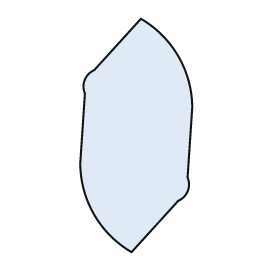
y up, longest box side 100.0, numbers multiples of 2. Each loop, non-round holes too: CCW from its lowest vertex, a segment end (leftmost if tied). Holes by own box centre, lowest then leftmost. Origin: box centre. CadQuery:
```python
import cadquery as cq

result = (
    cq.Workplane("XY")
    .moveTo(-2.0, -50.0)
    .lineTo(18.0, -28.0)
    .threePointArc((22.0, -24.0), (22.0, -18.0))
    .lineTo(24.0, 12.0)
    .threePointArc((18.0, 34.0), (2.0, 50.0))
    .lineTo(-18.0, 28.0)
    .threePointArc((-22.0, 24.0), (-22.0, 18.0))
    .lineTo(-24.0, -12.0)
    .threePointArc((-18.0, -34.0), (-2.0, -50.0))
    .close()
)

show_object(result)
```